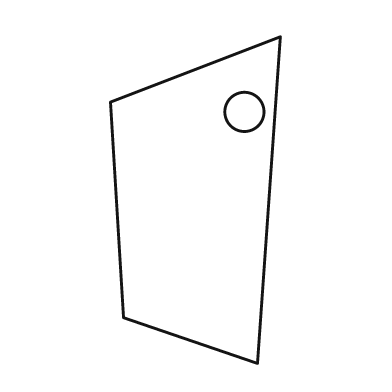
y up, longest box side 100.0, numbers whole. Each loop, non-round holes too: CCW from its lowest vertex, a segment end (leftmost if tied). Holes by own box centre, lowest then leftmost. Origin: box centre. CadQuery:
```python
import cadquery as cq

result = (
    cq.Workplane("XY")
    .moveTo(19.0, -50.0)
    .lineTo(26.0, 50.0)
    .lineTo(-26.0, 30.0)
    .lineTo(-22.0, -36.0)
    .close()
    .moveTo(15.0, 27.0)
    .circle(6.0)
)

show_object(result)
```